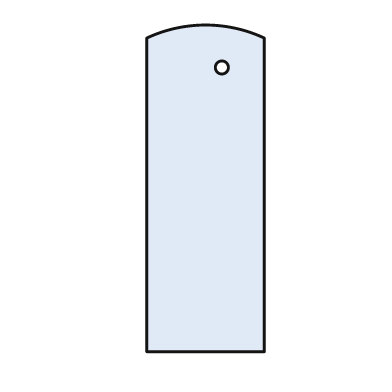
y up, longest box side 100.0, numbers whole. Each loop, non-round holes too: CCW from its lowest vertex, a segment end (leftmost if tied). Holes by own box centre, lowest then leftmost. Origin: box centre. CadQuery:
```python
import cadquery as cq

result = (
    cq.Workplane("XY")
    .moveTo(-18.0, -50.0)
    .lineTo(18.0, -50.0)
    .lineTo(18.0, 46.0)
    .threePointArc((0.0, 50.0), (-18.0, 46.0))
    .close()
    .moveTo(5.0, 37.0)
    .circle(2.0)
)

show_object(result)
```